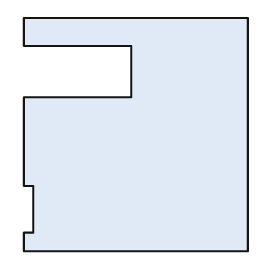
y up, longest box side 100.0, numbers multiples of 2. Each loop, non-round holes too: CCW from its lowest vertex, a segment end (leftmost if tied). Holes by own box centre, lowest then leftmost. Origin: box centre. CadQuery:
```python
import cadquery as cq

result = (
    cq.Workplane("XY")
    .moveTo(-48.0, -50.0)
    .lineTo(48.0, -50.0)
    .lineTo(48.0, 50.0)
    .lineTo(-48.0, 50.0)
    .lineTo(-48.0, 38.0)
    .lineTo(-2.0, 38.0)
    .lineTo(-2.0, 16.0)
    .lineTo(-48.0, 16.0)
    .lineTo(-48.0, -22.0)
    .lineTo(-44.0, -22.0)
    .lineTo(-44.0, -42.0)
    .lineTo(-48.0, -42.0)
    .close()
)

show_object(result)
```